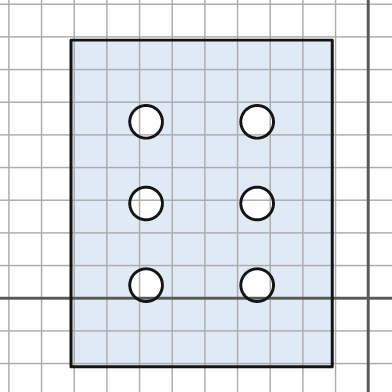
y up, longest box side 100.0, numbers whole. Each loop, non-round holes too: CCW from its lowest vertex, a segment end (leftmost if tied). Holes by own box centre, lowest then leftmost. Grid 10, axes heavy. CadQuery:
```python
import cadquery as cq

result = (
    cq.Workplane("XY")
    .moveTo(-91.0, -21.0)
    .lineTo(-11.0, -21.0)
    .lineTo(-11.0, 79.0)
    .lineTo(-91.0, 79.0)
    .close()
    .moveTo(-68.0, 4.0)
    .circle(5.0)
    .moveTo(-34.0, 4.0)
    .circle(5.0)
    .moveTo(-68.0, 29.0)
    .circle(5.0)
    .moveTo(-34.0, 29.0)
    .circle(5.0)
    .moveTo(-68.0, 54.0)
    .circle(5.0)
    .moveTo(-34.0, 54.0)
    .circle(5.0)
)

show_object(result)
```